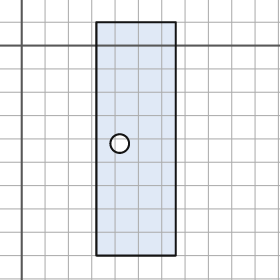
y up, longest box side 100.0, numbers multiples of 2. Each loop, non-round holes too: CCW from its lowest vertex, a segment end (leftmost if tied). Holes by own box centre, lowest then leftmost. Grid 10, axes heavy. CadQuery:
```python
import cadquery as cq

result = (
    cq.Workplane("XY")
    .moveTo(32.0, -90.0)
    .lineTo(66.0, -90.0)
    .lineTo(66.0, 10.0)
    .lineTo(32.0, 10.0)
    .close()
    .moveTo(42.0, -42.0)
    .circle(4.0)
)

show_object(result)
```